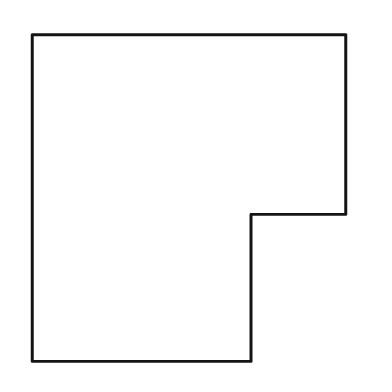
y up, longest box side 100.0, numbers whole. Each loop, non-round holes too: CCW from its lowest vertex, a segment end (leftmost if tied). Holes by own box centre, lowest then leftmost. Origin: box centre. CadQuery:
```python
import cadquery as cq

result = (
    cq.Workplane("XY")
    .moveTo(-48.0, -50.0)
    .lineTo(19.0, -50.0)
    .lineTo(19.0, -5.0)
    .lineTo(48.0, -5.0)
    .lineTo(48.0, 50.0)
    .lineTo(-48.0, 50.0)
    .close()
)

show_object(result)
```